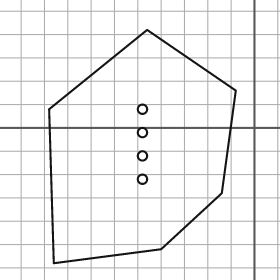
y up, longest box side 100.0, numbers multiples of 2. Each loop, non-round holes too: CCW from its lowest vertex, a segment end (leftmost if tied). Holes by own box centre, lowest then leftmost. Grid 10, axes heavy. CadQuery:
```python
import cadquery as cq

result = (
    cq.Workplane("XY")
    .moveTo(-86.0, -58.0)
    .lineTo(-40.0, -52.0)
    .lineTo(-14.0, -28.0)
    .lineTo(-8.0, 16.0)
    .lineTo(-46.0, 42.0)
    .lineTo(-88.0, 8.0)
    .close()
    .moveTo(-48.0, -22.0)
    .circle(2.0)
    .moveTo(-48.0, -12.0)
    .circle(2.0)
    .moveTo(-48.0, -2.0)
    .circle(2.0)
    .moveTo(-48.0, 8.0)
    .circle(2.0)
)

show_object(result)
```